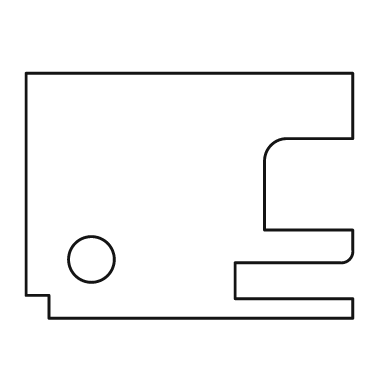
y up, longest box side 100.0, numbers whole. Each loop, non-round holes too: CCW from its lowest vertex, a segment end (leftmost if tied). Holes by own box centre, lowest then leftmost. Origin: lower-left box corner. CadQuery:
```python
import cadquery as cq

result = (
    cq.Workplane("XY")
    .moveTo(7.0, 0.0)
    .lineTo(100.0, 0.0)
    .lineTo(100.0, 6.0)
    .lineTo(64.0, 6.0)
    .lineTo(64.0, 17.0)
    .lineTo(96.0, 17.0)
    .threePointArc((99.0, 18.0), (100.0, 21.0))
    .lineTo(100.0, 27.0)
    .lineTo(73.0, 27.0)
    .lineTo(73.0, 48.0)
    .threePointArc((75.0, 53.0), (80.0, 55.0))
    .lineTo(100.0, 55.0)
    .lineTo(100.0, 75.0)
    .lineTo(0.0, 75.0)
    .lineTo(0.0, 7.0)
    .lineTo(7.0, 7.0)
    .close()
    .moveTo(20.0, 18.0)
    .circle(7.0)
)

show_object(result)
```